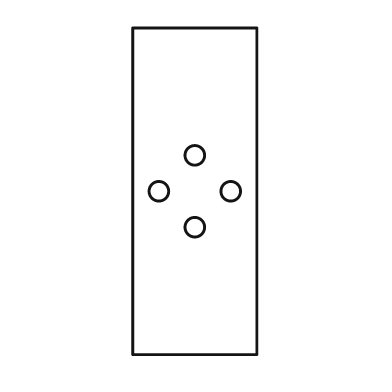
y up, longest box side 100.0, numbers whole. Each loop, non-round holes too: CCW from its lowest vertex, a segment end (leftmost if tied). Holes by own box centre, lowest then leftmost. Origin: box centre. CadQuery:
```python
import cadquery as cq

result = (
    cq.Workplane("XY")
    .moveTo(-19.0, -50.0)
    .lineTo(19.0, -50.0)
    .lineTo(19.0, 50.0)
    .lineTo(-19.0, 50.0)
    .close()
    .moveTo(0.0, -11.0)
    .circle(3.0)
    .moveTo(-11.0, 0.0)
    .circle(3.0)
    .moveTo(11.0, 0.0)
    .circle(3.0)
    .moveTo(0.0, 11.0)
    .circle(3.0)
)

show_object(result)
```